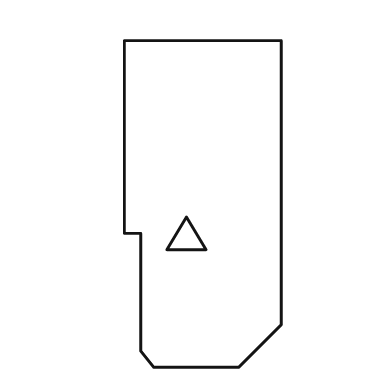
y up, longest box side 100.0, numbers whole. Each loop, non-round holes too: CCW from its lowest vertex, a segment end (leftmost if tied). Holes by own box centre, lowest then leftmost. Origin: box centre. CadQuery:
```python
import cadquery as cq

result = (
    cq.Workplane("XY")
    .moveTo(-15.0, -50.0)
    .lineTo(11.0, -50.0)
    .lineTo(24.0, -37.0)
    .lineTo(24.0, 50.0)
    .lineTo(-24.0, 50.0)
    .lineTo(-24.0, -9.0)
    .lineTo(-19.0, -9.0)
    .lineTo(-19.0, -45.0)
    .close()
    .moveTo(-11.0, -14.0)
    .lineTo(1.0, -14.0)
    .lineTo(-5.0, -4.0)
    .close()
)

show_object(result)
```